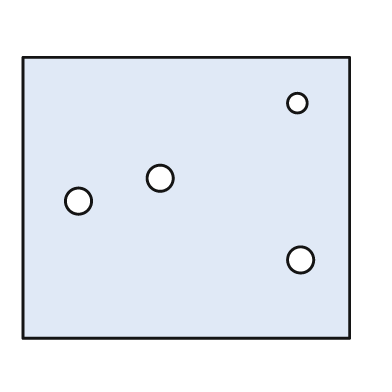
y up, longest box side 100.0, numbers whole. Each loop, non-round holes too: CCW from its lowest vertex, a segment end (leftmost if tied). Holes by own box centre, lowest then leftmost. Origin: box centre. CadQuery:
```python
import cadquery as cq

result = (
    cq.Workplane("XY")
    .moveTo(-50.0, -43.0)
    .lineTo(50.0, -43.0)
    .lineTo(50.0, 43.0)
    .lineTo(-50.0, 43.0)
    .close()
    .moveTo(35.0, -19.0)
    .circle(4.0)
    .moveTo(-33.0, -1.0)
    .circle(4.0)
    .moveTo(-8.0, 6.0)
    .circle(4.0)
    .moveTo(34.0, 29.0)
    .circle(3.0)
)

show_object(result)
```